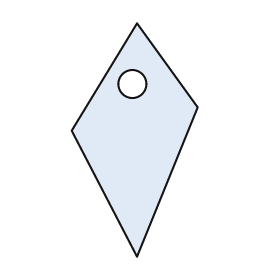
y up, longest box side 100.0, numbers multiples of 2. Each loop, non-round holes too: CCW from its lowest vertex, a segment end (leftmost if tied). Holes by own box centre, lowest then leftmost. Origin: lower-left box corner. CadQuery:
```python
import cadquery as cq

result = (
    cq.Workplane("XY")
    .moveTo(28.0, 0.0)
    .lineTo(54.0, 64.0)
    .lineTo(28.0, 100.0)
    .lineTo(0.0, 54.0)
    .close()
    .moveTo(26.0, 74.0)
    .circle(6.0)
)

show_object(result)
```